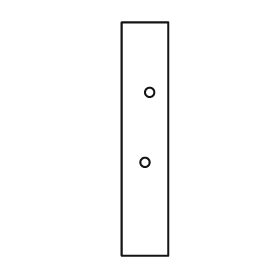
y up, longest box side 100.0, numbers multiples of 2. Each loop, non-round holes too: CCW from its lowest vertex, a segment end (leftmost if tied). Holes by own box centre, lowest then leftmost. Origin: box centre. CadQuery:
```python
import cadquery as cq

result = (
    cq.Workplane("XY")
    .moveTo(-10.0, -50.0)
    .lineTo(10.0, -50.0)
    .lineTo(10.0, 50.0)
    .lineTo(-10.0, 50.0)
    .close()
    .moveTo(0.0, -10.0)
    .circle(2.0)
    .moveTo(2.0, 20.0)
    .circle(2.0)
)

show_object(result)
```